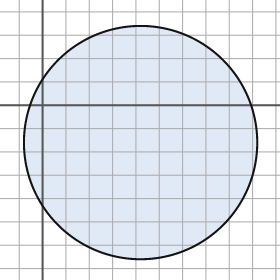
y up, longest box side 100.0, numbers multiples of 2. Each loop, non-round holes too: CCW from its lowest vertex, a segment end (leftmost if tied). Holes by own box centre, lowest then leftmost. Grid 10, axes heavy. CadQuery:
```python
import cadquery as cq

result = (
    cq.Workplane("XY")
    .moveTo(42.0, -16.0)
    .circle(50.0)
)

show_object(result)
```